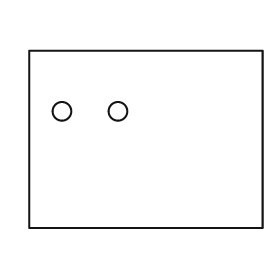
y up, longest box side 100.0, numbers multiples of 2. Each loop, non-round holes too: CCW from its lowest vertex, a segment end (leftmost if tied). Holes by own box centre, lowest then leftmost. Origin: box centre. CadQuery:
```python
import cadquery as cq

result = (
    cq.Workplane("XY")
    .moveTo(-50.0, -38.0)
    .lineTo(50.0, -38.0)
    .lineTo(50.0, 38.0)
    .lineTo(-50.0, 38.0)
    .close()
    .moveTo(-36.0, 12.0)
    .circle(4.0)
    .moveTo(-12.0, 12.0)
    .circle(4.0)
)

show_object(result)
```